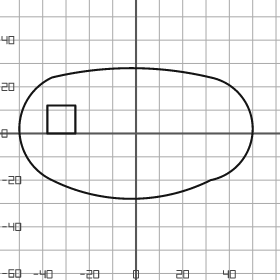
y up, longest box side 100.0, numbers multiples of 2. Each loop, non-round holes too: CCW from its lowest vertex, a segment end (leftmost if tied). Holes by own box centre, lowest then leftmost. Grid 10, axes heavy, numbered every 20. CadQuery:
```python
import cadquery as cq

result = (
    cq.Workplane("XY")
    .moveTo(-36.0, -20.0)
    .threePointArc((-2.0, -28.0), (32.0, -20.0))
    .threePointArc((50.0, 2.0), (32.0, 24.0))
    .threePointArc((-2.0, 28.0), (-36.0, 24.0))
    .threePointArc((-50.0, 2.0), (-36.0, -20.0))
    .close()
    .moveTo(-38.0, 0.0)
    .lineTo(-26.0, 0.0)
    .lineTo(-26.0, 12.0)
    .lineTo(-38.0, 12.0)
    .close()
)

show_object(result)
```